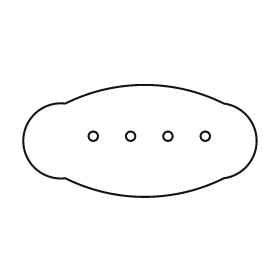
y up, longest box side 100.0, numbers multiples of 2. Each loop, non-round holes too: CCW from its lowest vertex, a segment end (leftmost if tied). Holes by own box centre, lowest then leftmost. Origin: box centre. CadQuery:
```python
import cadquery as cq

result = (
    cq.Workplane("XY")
    .moveTo(-32.0, -16.0)
    .threePointArc((2.0, -24.0), (36.0, -16.0))
    .threePointArc((50.0, 0.0), (36.0, 16.0))
    .threePointArc((2.0, 24.0), (-32.0, 16.0))
    .threePointArc((-50.0, 0.0), (-32.0, -16.0))
    .close()
    .moveTo(-20.0, 2.0)
    .circle(2.0)
    .moveTo(-4.0, 2.0)
    .circle(2.0)
    .moveTo(12.0, 2.0)
    .circle(2.0)
    .moveTo(28.0, 2.0)
    .circle(2.0)
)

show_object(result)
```